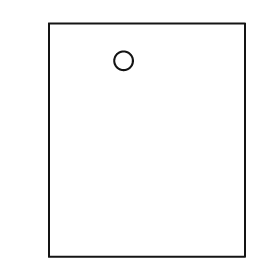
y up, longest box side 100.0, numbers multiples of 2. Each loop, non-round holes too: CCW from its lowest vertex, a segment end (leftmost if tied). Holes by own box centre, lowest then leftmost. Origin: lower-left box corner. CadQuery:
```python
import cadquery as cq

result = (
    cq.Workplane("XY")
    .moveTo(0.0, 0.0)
    .lineTo(84.0, 0.0)
    .lineTo(84.0, 100.0)
    .lineTo(0.0, 100.0)
    .close()
    .moveTo(32.0, 84.0)
    .circle(4.0)
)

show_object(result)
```